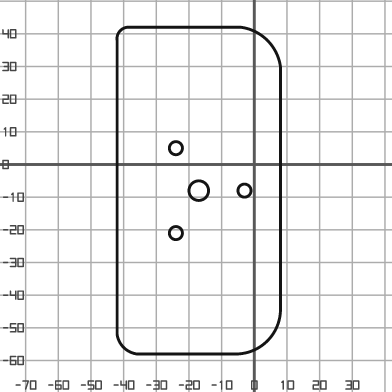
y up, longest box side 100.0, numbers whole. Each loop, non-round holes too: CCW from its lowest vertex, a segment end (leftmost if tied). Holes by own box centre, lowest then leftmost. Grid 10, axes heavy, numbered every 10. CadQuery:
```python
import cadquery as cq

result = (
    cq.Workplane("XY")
    .moveTo(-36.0, -58.0)
    .lineTo(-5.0, -58.0)
    .threePointArc((4.0, -54.0), (8.0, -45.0))
    .lineTo(8.0, 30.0)
    .threePointArc((4.0, 38.0), (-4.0, 42.0))
    .lineTo(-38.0, 42.0)
    .threePointArc((-41.0, 41.0), (-42.0, 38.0))
    .lineTo(-42.0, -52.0)
    .threePointArc((-40.0, -56.0), (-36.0, -58.0))
    .close()
    .moveTo(-24.0, -21.0)
    .circle(2.0)
    .moveTo(-17.0, -8.0)
    .circle(3.0)
    .moveTo(-3.0, -8.0)
    .circle(2.0)
    .moveTo(-24.0, 5.0)
    .circle(2.0)
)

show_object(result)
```